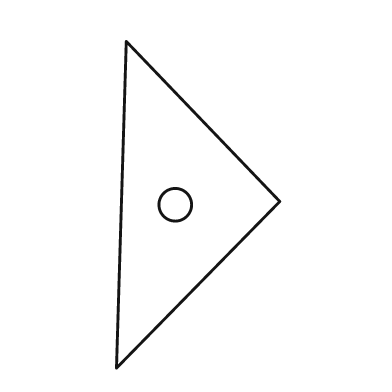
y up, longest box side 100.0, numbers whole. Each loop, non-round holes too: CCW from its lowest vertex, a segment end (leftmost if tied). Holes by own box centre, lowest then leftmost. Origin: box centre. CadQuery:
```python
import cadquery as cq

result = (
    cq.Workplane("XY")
    .moveTo(-25.0, -50.0)
    .lineTo(25.0, 1.0)
    .lineTo(-22.0, 50.0)
    .close()
    .moveTo(-7.0, 0.0)
    .circle(5.0)
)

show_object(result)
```